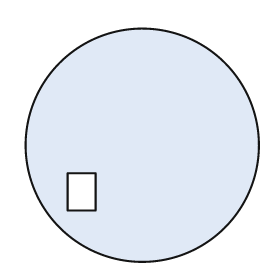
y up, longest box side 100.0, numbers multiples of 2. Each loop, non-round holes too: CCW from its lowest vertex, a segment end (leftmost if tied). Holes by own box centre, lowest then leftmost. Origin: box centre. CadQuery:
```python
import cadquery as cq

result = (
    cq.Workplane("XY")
    .moveTo(0.0, 0.0)
    .circle(50.0)
    .moveTo(-32.0, -28.0)
    .lineTo(-20.0, -28.0)
    .lineTo(-20.0, -12.0)
    .lineTo(-32.0, -12.0)
    .close()
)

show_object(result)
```